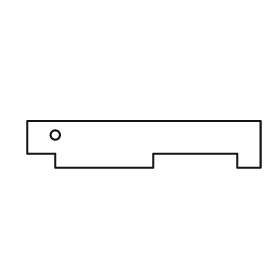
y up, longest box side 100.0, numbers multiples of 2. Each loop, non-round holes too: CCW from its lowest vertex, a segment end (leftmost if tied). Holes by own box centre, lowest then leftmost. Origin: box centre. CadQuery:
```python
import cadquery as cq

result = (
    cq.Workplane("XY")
    .moveTo(-38.0, -10.0)
    .lineTo(4.0, -10.0)
    .lineTo(4.0, -4.0)
    .lineTo(40.0, -4.0)
    .lineTo(40.0, -10.0)
    .lineTo(50.0, -10.0)
    .lineTo(50.0, 10.0)
    .lineTo(-50.0, 10.0)
    .lineTo(-50.0, -4.0)
    .lineTo(-38.0, -4.0)
    .close()
    .moveTo(-38.0, 4.0)
    .circle(2.0)
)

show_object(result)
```